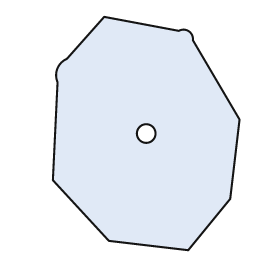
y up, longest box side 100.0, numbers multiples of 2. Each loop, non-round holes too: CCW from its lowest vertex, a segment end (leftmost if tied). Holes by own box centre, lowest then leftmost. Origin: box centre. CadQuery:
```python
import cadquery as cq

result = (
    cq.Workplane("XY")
    .moveTo(18.0, -50.0)
    .lineTo(36.0, -28.0)
    .lineTo(40.0, 6.0)
    .lineTo(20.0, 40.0)
    .threePointArc((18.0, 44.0), (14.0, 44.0))
    .lineTo(-18.0, 50.0)
    .lineTo(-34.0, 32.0)
    .threePointArc((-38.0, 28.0), (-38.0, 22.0))
    .lineTo(-40.0, -20.0)
    .lineTo(-16.0, -46.0)
    .close()
    .moveTo(0.0, 0.0)
    .circle(4.0)
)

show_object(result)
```